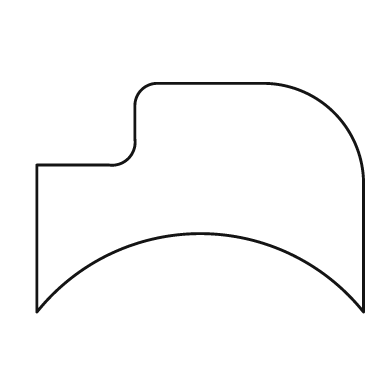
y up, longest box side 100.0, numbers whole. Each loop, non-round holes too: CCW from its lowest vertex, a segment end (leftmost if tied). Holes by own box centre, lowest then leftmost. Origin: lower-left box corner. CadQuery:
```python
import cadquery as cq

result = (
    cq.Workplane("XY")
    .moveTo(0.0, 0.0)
    .threePointArc((50.0, 24.0), (100.0, 0.0))
    .lineTo(100.0, 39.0)
    .threePointArc((91.0, 61.0), (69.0, 70.0))
    .lineTo(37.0, 70.0)
    .threePointArc((32.0, 68.0), (30.0, 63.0))
    .lineTo(30.0, 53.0)
    .threePointArc((28.0, 47.0), (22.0, 45.0))
    .lineTo(0.0, 45.0)
    .close()
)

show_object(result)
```